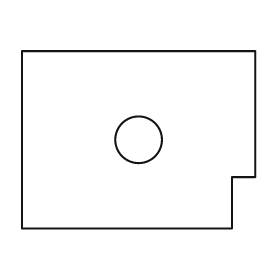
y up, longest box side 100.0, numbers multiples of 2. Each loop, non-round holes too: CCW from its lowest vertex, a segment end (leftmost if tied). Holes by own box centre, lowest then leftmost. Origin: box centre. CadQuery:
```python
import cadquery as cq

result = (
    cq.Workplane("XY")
    .moveTo(-50.0, -38.0)
    .lineTo(40.0, -38.0)
    .lineTo(40.0, -16.0)
    .lineTo(50.0, -16.0)
    .lineTo(50.0, 38.0)
    .lineTo(-50.0, 38.0)
    .close()
    .moveTo(0.0, 0.0)
    .circle(10.0)
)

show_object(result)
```